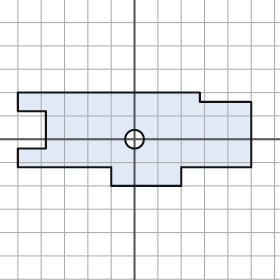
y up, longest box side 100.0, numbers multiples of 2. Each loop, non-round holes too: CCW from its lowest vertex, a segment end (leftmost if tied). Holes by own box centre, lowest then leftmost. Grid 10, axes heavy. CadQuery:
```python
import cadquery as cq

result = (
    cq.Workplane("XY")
    .moveTo(-10.0, -20.0)
    .lineTo(20.0, -20.0)
    .lineTo(20.0, -12.0)
    .lineTo(50.0, -12.0)
    .lineTo(50.0, 16.0)
    .lineTo(28.0, 16.0)
    .lineTo(28.0, 20.0)
    .lineTo(-50.0, 20.0)
    .lineTo(-50.0, 12.0)
    .lineTo(-38.0, 12.0)
    .lineTo(-38.0, -4.0)
    .lineTo(-50.0, -4.0)
    .lineTo(-50.0, -12.0)
    .lineTo(-10.0, -12.0)
    .close()
    .moveTo(0.0, 0.0)
    .circle(4.0)
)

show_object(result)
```